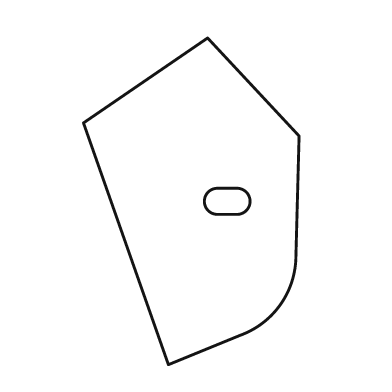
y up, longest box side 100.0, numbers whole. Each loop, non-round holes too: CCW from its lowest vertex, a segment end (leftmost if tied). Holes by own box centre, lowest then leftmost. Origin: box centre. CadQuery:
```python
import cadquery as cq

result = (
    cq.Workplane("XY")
    .moveTo(-7.0, -50.0)
    .lineTo(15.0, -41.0)
    .threePointArc((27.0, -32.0), (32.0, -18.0))
    .lineTo(33.0, 20.0)
    .lineTo(5.0, 50.0)
    .lineTo(-33.0, 24.0)
    .close()
    .moveTo(8.0, -4.0)
    .lineTo(14.0, -4.0)
    .threePointArc((18.0, 0.0), (14.0, 4.0))
    .lineTo(8.0, 4.0)
    .threePointArc((4.0, 0.0), (8.0, -4.0))
    .close()
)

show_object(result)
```